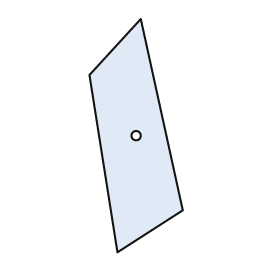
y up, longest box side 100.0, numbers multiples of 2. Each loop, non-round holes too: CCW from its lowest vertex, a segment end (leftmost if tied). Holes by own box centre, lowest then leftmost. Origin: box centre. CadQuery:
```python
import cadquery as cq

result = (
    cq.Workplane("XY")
    .moveTo(-8.0, -50.0)
    .lineTo(20.0, -32.0)
    .lineTo(2.0, 50.0)
    .lineTo(-20.0, 26.0)
    .close()
    .moveTo(0.0, 0.0)
    .circle(2.0)
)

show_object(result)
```